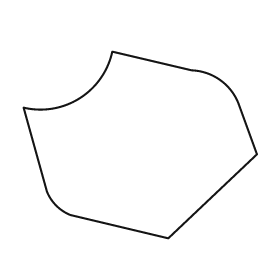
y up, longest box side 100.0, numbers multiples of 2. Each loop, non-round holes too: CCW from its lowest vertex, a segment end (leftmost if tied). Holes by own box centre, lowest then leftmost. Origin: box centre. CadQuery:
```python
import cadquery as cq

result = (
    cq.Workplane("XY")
    .moveTo(12.0, -40.0)
    .lineTo(50.0, -4.0)
    .lineTo(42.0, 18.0)
    .threePointArc((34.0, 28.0), (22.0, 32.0))
    .lineTo(-12.0, 40.0)
    .threePointArc((-26.0, 20.0), (-50.0, 16.0))
    .lineTo(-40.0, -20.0)
    .threePointArc((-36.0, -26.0), (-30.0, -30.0))
    .close()
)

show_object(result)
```